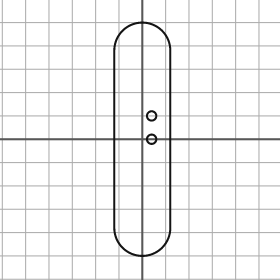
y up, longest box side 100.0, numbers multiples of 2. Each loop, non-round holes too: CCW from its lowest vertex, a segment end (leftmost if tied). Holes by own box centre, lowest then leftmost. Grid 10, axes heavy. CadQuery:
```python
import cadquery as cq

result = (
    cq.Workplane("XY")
    .moveTo(-12.0, -38.0)
    .threePointArc((0.0, -50.0), (12.0, -38.0))
    .lineTo(12.0, 38.0)
    .threePointArc((0.0, 50.0), (-12.0, 38.0))
    .close()
    .moveTo(4.0, 0.0)
    .circle(2.0)
    .moveTo(4.0, 10.0)
    .circle(2.0)
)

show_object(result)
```